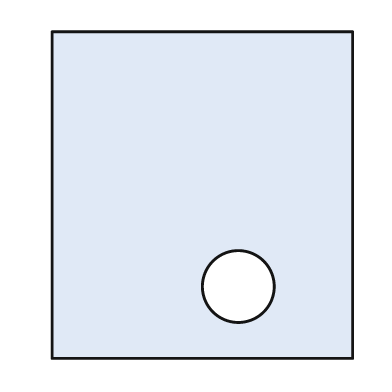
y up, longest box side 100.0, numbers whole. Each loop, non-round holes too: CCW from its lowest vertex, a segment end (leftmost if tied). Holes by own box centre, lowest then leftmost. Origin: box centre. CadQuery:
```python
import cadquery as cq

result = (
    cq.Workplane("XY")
    .moveTo(-46.0, -50.0)
    .lineTo(46.0, -50.0)
    .lineTo(46.0, 50.0)
    .lineTo(-46.0, 50.0)
    .close()
    .moveTo(11.0, -28.0)
    .circle(11.0)
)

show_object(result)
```